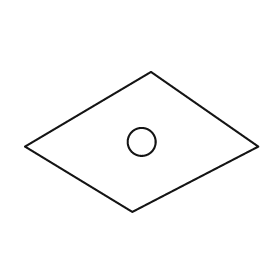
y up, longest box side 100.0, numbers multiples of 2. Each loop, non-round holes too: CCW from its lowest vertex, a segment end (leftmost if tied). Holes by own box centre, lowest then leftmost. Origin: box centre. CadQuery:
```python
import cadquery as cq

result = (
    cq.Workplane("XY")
    .moveTo(-4.0, -30.0)
    .lineTo(50.0, -2.0)
    .lineTo(4.0, 30.0)
    .lineTo(-50.0, -2.0)
    .close()
    .moveTo(0.0, 0.0)
    .circle(6.0)
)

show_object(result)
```